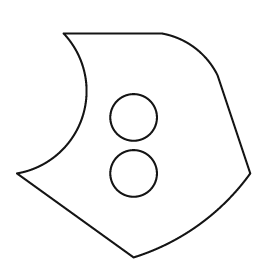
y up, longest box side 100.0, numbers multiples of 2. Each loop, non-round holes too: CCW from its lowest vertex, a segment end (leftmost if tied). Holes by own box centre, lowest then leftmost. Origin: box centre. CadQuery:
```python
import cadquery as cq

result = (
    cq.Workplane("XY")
    .moveTo(0.0, -48.0)
    .threePointArc((28.0, -34.0), (50.0, -12.0))
    .lineTo(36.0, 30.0)
    .threePointArc((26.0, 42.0), (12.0, 48.0))
    .lineTo(-30.0, 48.0)
    .threePointArc((-22.0, 12.0), (-50.0, -12.0))
    .close()
    .moveTo(0.0, -12.0)
    .circle(10.0)
    .moveTo(0.0, 12.0)
    .circle(10.0)
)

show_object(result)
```